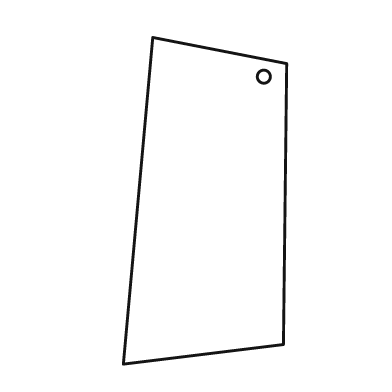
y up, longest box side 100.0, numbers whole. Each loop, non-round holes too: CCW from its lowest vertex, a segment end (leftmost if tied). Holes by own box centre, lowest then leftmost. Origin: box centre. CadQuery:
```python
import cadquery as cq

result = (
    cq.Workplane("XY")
    .moveTo(-25.0, -50.0)
    .lineTo(24.0, -44.0)
    .lineTo(25.0, 42.0)
    .lineTo(-16.0, 50.0)
    .close()
    .moveTo(18.0, 38.0)
    .circle(2.0)
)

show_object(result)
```